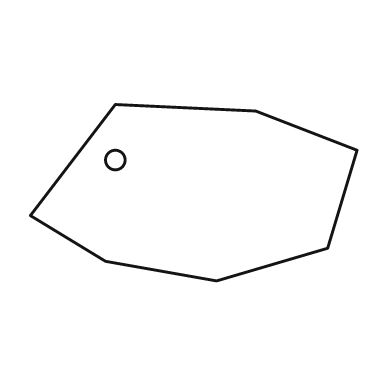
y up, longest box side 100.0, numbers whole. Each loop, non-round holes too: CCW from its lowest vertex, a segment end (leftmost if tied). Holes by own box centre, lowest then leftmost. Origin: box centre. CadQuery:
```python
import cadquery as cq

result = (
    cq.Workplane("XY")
    .moveTo(7.0, -27.0)
    .lineTo(41.0, -17.0)
    .lineTo(50.0, 13.0)
    .lineTo(19.0, 25.0)
    .lineTo(-24.0, 27.0)
    .lineTo(-50.0, -7.0)
    .lineTo(-27.0, -21.0)
    .close()
    .moveTo(-24.0, 10.0)
    .circle(3.0)
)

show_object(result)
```